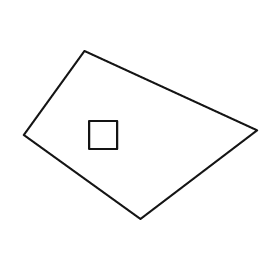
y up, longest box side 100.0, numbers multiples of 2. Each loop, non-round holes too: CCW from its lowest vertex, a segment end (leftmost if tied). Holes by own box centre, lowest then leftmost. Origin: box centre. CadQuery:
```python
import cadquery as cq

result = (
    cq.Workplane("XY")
    .moveTo(0.0, -36.0)
    .lineTo(50.0, 2.0)
    .lineTo(-24.0, 36.0)
    .lineTo(-50.0, 0.0)
    .close()
    .moveTo(-22.0, -6.0)
    .lineTo(-10.0, -6.0)
    .lineTo(-10.0, 6.0)
    .lineTo(-22.0, 6.0)
    .close()
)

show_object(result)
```